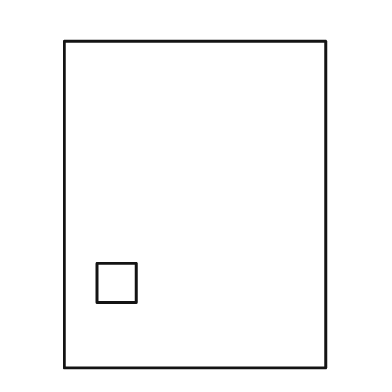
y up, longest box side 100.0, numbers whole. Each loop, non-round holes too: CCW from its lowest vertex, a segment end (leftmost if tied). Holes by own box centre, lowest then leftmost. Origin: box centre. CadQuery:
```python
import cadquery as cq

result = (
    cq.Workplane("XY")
    .moveTo(-40.0, -50.0)
    .lineTo(40.0, -50.0)
    .lineTo(40.0, 50.0)
    .lineTo(-40.0, 50.0)
    .close()
    .moveTo(-30.0, -30.0)
    .lineTo(-18.0, -30.0)
    .lineTo(-18.0, -18.0)
    .lineTo(-30.0, -18.0)
    .close()
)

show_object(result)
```